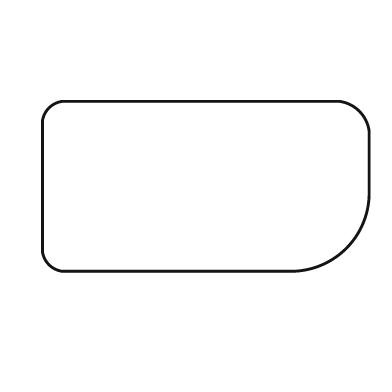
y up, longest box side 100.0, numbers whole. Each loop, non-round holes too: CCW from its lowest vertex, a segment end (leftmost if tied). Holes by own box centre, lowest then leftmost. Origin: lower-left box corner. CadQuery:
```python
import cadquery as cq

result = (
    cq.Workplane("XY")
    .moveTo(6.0, 0.0)
    .lineTo(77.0, 0.0)
    .threePointArc((93.0, 7.0), (100.0, 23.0))
    .lineTo(100.0, 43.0)
    .threePointArc((97.0, 49.0), (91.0, 52.0))
    .lineTo(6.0, 52.0)
    .threePointArc((2.0, 50.0), (0.0, 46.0))
    .lineTo(0.0, 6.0)
    .threePointArc((2.0, 2.0), (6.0, 0.0))
    .close()
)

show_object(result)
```